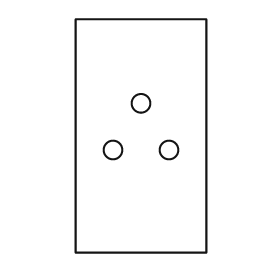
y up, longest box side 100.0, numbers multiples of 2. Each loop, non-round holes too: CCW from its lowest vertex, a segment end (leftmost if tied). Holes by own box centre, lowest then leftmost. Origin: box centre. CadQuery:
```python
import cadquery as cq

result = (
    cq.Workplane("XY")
    .moveTo(-28.0, -50.0)
    .lineTo(28.0, -50.0)
    .lineTo(28.0, 50.0)
    .lineTo(-28.0, 50.0)
    .close()
    .moveTo(-12.0, -6.0)
    .circle(4.0)
    .moveTo(12.0, -6.0)
    .circle(4.0)
    .moveTo(0.0, 14.0)
    .circle(4.0)
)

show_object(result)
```